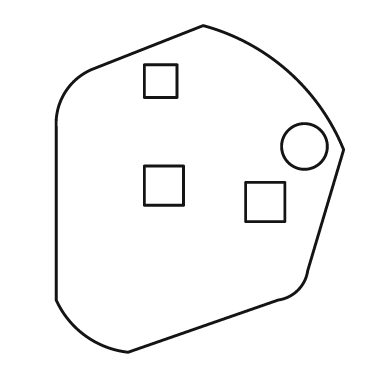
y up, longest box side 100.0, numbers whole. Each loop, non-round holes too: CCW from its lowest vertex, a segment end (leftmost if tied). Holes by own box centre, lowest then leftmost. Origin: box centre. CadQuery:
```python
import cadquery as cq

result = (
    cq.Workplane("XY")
    .moveTo(-22.0, -50.0)
    .lineTo(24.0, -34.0)
    .threePointArc((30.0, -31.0), (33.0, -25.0))
    .lineTo(44.0, 12.0)
    .threePointArc((27.0, 36.0), (1.0, 50.0))
    .lineTo(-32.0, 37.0)
    .threePointArc((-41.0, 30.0), (-44.0, 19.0))
    .lineTo(-44.0, -34.0)
    .threePointArc((-35.0, -45.0), (-22.0, -50.0))
    .close()
    .moveTo(14.0, -10.0)
    .lineTo(26.0, -10.0)
    .lineTo(26.0, 2.0)
    .lineTo(14.0, 2.0)
    .close()
    .moveTo(-17.0, -5.0)
    .lineTo(-5.0, -5.0)
    .lineTo(-5.0, 7.0)
    .lineTo(-17.0, 7.0)
    .close()
    .moveTo(32.0, 13.0)
    .circle(7.0)
    .moveTo(-17.0, 28.0)
    .lineTo(-7.0, 28.0)
    .lineTo(-7.0, 38.0)
    .lineTo(-17.0, 38.0)
    .close()
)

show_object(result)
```